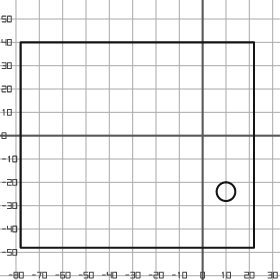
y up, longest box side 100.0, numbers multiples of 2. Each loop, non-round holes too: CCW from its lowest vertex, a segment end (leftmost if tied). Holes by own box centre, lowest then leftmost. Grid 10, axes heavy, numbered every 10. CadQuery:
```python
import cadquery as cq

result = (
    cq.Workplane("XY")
    .moveTo(-78.0, -48.0)
    .lineTo(22.0, -48.0)
    .lineTo(22.0, 40.0)
    .lineTo(-78.0, 40.0)
    .close()
    .moveTo(10.0, -24.0)
    .circle(4.0)
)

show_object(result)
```